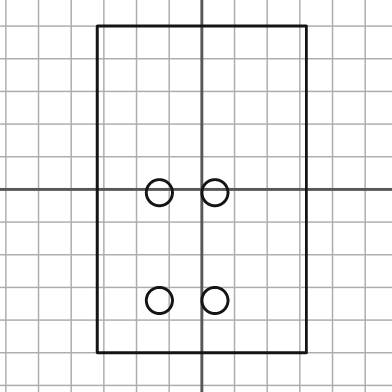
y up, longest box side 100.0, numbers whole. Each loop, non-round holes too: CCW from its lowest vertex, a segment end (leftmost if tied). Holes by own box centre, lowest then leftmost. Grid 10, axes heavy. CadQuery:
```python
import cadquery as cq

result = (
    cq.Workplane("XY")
    .moveTo(-32.0, -50.0)
    .lineTo(32.0, -50.0)
    .lineTo(32.0, 50.0)
    .lineTo(-32.0, 50.0)
    .close()
    .moveTo(-13.0, -34.0)
    .circle(4.0)
    .moveTo(4.0, -34.0)
    .circle(4.0)
    .moveTo(-13.0, -1.0)
    .circle(4.0)
    .moveTo(4.0, -1.0)
    .circle(4.0)
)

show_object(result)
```